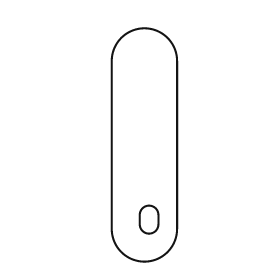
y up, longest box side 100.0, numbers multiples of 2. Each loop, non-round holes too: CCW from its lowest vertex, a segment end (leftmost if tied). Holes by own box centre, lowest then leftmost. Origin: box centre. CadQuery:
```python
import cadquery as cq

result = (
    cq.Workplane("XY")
    .moveTo(-14.0, -36.0)
    .threePointArc((0.0, -50.0), (14.0, -36.0))
    .lineTo(14.0, 36.0)
    .threePointArc((0.0, 50.0), (-14.0, 36.0))
    .close()
    .moveTo(-2.0, -34.0)
    .threePointArc((2.0, -38.0), (6.0, -34.0))
    .lineTo(6.0, -30.0)
    .threePointArc((2.0, -26.0), (-2.0, -30.0))
    .close()
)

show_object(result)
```